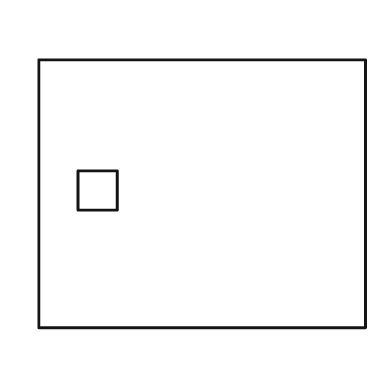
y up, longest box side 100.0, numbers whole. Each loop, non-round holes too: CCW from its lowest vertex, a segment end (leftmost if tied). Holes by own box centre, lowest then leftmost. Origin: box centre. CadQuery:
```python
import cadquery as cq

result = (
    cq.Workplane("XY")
    .moveTo(-50.0, -41.0)
    .lineTo(50.0, -41.0)
    .lineTo(50.0, 41.0)
    .lineTo(-50.0, 41.0)
    .close()
    .moveTo(-38.0, -5.0)
    .lineTo(-26.0, -5.0)
    .lineTo(-26.0, 7.0)
    .lineTo(-38.0, 7.0)
    .close()
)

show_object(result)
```